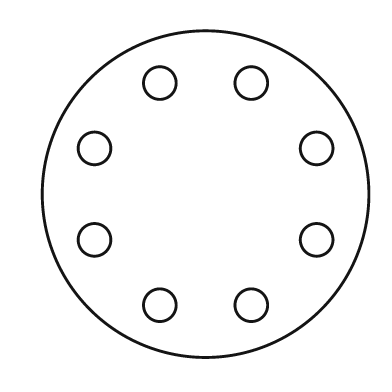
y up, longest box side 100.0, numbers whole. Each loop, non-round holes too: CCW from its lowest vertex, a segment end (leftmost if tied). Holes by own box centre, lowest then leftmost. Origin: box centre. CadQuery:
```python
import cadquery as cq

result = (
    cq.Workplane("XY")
    .moveTo(0.0, 0.0)
    .circle(50.0)
    .moveTo(-14.0, -34.0)
    .circle(5.0)
    .moveTo(14.0, -34.0)
    .circle(5.0)
    .moveTo(-34.0, -14.0)
    .circle(5.0)
    .moveTo(34.0, -14.0)
    .circle(5.0)
    .moveTo(-34.0, 14.0)
    .circle(5.0)
    .moveTo(34.0, 14.0)
    .circle(5.0)
    .moveTo(-14.0, 34.0)
    .circle(5.0)
    .moveTo(14.0, 34.0)
    .circle(5.0)
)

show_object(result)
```